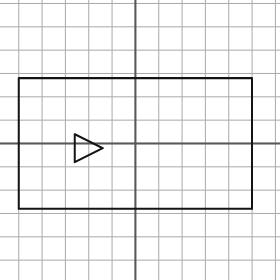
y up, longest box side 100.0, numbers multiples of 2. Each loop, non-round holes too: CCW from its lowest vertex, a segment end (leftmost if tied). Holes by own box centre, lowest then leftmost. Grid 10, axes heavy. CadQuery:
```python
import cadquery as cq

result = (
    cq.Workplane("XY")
    .moveTo(-50.0, -28.0)
    .lineTo(50.0, -28.0)
    .lineTo(50.0, 28.0)
    .lineTo(-50.0, 28.0)
    .close()
    .moveTo(-26.0, -8.0)
    .lineTo(-14.0, -2.0)
    .lineTo(-26.0, 4.0)
    .close()
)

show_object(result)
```